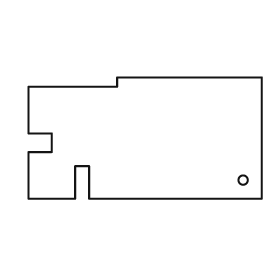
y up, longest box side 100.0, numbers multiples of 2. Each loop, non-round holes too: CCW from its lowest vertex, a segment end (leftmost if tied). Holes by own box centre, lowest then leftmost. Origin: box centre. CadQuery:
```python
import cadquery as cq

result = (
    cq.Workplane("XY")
    .moveTo(-50.0, -26.0)
    .lineTo(-30.0, -26.0)
    .lineTo(-30.0, -12.0)
    .lineTo(-24.0, -12.0)
    .lineTo(-24.0, -26.0)
    .lineTo(50.0, -26.0)
    .lineTo(50.0, 26.0)
    .lineTo(-12.0, 26.0)
    .lineTo(-12.0, 22.0)
    .lineTo(-50.0, 22.0)
    .lineTo(-50.0, 2.0)
    .lineTo(-40.0, 2.0)
    .lineTo(-40.0, -6.0)
    .lineTo(-50.0, -6.0)
    .close()
    .moveTo(42.0, -18.0)
    .circle(2.0)
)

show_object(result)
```